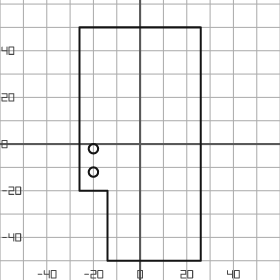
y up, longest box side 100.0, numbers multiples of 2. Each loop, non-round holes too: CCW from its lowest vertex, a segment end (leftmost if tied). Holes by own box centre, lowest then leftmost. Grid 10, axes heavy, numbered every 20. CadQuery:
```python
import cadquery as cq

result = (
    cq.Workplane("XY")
    .moveTo(-14.0, -50.0)
    .lineTo(26.0, -50.0)
    .lineTo(26.0, 50.0)
    .lineTo(-26.0, 50.0)
    .lineTo(-26.0, -20.0)
    .lineTo(-14.0, -20.0)
    .close()
    .moveTo(-20.0, -12.0)
    .circle(2.0)
    .moveTo(-20.0, -2.0)
    .circle(2.0)
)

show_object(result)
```